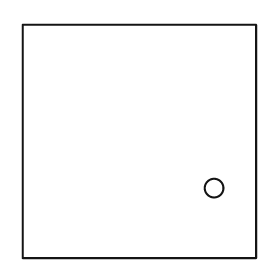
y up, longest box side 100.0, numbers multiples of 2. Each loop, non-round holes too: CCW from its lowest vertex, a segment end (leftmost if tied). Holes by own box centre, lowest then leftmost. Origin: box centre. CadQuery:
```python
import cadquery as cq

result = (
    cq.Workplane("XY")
    .moveTo(-50.0, -50.0)
    .lineTo(50.0, -50.0)
    .lineTo(50.0, 50.0)
    .lineTo(-50.0, 50.0)
    .close()
    .moveTo(32.0, -20.0)
    .circle(4.0)
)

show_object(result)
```